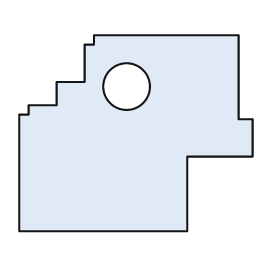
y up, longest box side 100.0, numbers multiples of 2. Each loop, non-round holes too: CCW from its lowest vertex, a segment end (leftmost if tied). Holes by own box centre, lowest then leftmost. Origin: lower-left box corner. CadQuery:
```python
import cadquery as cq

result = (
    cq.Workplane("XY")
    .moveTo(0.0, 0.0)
    .lineTo(72.0, 0.0)
    .lineTo(72.0, 32.0)
    .lineTo(100.0, 32.0)
    .lineTo(100.0, 48.0)
    .lineTo(94.0, 48.0)
    .lineTo(94.0, 84.0)
    .lineTo(32.0, 84.0)
    .lineTo(32.0, 80.0)
    .lineTo(28.0, 80.0)
    .lineTo(28.0, 64.0)
    .lineTo(16.0, 64.0)
    .lineTo(16.0, 54.0)
    .lineTo(4.0, 54.0)
    .lineTo(4.0, 50.0)
    .lineTo(0.0, 50.0)
    .close()
    .moveTo(46.0, 62.0)
    .circle(10.0)
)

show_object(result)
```